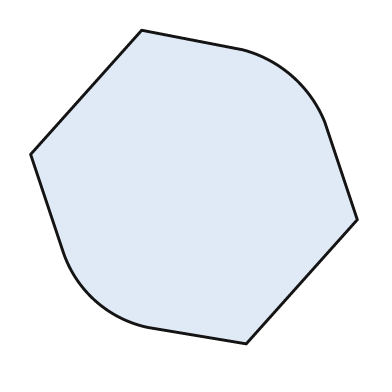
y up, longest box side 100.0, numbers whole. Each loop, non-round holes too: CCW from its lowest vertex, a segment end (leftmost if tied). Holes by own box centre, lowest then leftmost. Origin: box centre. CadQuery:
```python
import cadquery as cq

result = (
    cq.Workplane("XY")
    .moveTo(16.0, -48.0)
    .lineTo(50.0, -10.0)
    .lineTo(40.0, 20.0)
    .threePointArc((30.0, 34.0), (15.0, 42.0))
    .lineTo(-16.0, 48.0)
    .lineTo(-50.0, 10.0)
    .lineTo(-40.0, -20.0)
    .threePointArc((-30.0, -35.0), (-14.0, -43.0))
    .close()
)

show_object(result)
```